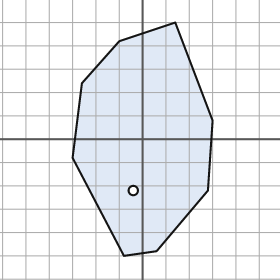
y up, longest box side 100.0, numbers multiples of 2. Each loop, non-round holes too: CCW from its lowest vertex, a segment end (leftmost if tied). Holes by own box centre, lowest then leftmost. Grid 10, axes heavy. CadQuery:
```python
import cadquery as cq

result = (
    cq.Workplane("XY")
    .moveTo(-8.0, -50.0)
    .lineTo(6.0, -48.0)
    .lineTo(28.0, -22.0)
    .lineTo(30.0, 8.0)
    .lineTo(14.0, 50.0)
    .lineTo(-10.0, 42.0)
    .lineTo(-26.0, 24.0)
    .lineTo(-30.0, -8.0)
    .close()
    .moveTo(-4.0, -22.0)
    .circle(2.0)
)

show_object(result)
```